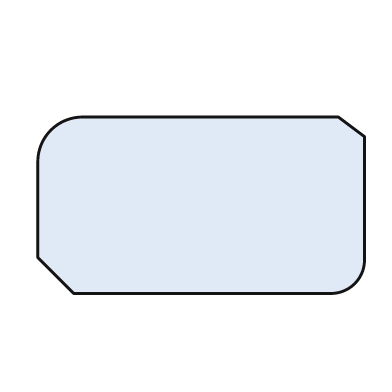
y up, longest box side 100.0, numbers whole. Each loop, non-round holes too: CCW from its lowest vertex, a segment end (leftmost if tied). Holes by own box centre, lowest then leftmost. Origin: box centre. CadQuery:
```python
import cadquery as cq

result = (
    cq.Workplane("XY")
    .moveTo(-39.0, -27.0)
    .lineTo(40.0, -27.0)
    .threePointArc((47.0, -24.0), (50.0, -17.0))
    .lineTo(50.0, 21.0)
    .lineTo(42.0, 27.0)
    .lineTo(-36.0, 27.0)
    .threePointArc((-46.0, 23.0), (-50.0, 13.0))
    .lineTo(-50.0, -16.0)
    .close()
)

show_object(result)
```